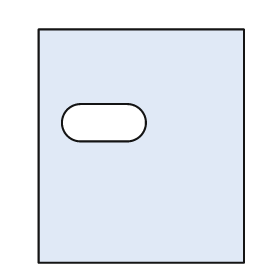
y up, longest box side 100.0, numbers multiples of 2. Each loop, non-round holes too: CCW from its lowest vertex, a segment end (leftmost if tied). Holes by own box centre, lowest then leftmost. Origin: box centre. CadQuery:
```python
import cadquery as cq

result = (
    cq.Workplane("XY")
    .moveTo(-44.0, -50.0)
    .lineTo(44.0, -50.0)
    .lineTo(44.0, 50.0)
    .lineTo(-44.0, 50.0)
    .close()
    .moveTo(-26.0, 2.0)
    .lineTo(-6.0, 2.0)
    .threePointArc((2.0, 10.0), (-6.0, 18.0))
    .lineTo(-26.0, 18.0)
    .threePointArc((-34.0, 10.0), (-26.0, 2.0))
    .close()
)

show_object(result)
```